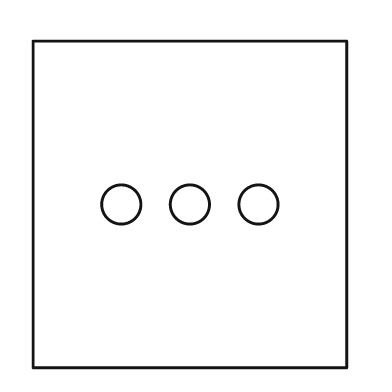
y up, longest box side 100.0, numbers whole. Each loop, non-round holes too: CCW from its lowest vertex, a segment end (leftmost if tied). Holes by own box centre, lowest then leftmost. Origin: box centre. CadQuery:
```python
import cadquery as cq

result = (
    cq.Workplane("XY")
    .moveTo(-48.0, -50.0)
    .lineTo(48.0, -50.0)
    .lineTo(48.0, 50.0)
    .lineTo(-48.0, 50.0)
    .close()
    .moveTo(-21.0, 0.0)
    .circle(6.0)
    .moveTo(0.0, 0.0)
    .circle(6.0)
    .moveTo(21.0, 0.0)
    .circle(6.0)
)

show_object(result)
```